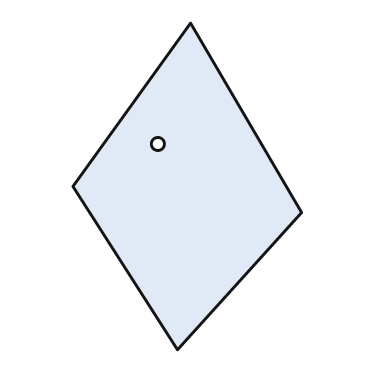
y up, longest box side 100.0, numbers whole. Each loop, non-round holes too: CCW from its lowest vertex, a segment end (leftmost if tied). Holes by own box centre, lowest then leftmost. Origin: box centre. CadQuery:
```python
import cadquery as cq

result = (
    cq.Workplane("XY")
    .moveTo(-3.0, -50.0)
    .lineTo(35.0, -8.0)
    .lineTo(1.0, 50.0)
    .lineTo(-35.0, 0.0)
    .close()
    .moveTo(-9.0, 13.0)
    .circle(2.0)
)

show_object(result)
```